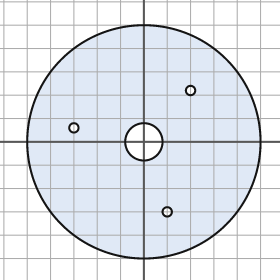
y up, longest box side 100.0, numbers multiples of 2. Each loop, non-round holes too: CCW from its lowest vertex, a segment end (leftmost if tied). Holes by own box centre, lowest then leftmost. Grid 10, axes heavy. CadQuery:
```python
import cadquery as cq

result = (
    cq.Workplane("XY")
    .moveTo(0.0, 0.0)
    .circle(50.0)
    .moveTo(10.0, -30.0)
    .circle(2.0)
    .moveTo(0.0, 0.0)
    .circle(8.0)
    .moveTo(-30.0, 6.0)
    .circle(2.0)
    .moveTo(20.0, 22.0)
    .circle(2.0)
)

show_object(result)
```